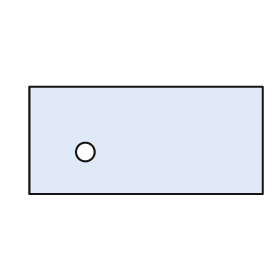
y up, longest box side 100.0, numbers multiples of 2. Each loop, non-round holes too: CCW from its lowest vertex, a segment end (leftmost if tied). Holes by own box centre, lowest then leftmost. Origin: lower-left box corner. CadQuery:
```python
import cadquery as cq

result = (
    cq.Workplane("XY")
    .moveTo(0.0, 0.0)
    .lineTo(100.0, 0.0)
    .lineTo(100.0, 46.0)
    .lineTo(0.0, 46.0)
    .close()
    .moveTo(24.0, 18.0)
    .circle(4.0)
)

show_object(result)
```